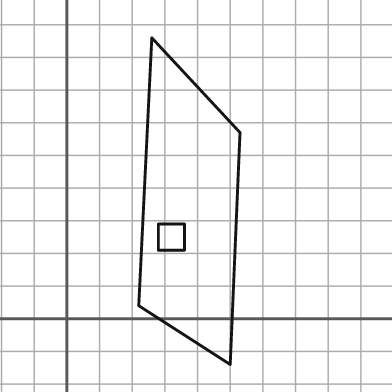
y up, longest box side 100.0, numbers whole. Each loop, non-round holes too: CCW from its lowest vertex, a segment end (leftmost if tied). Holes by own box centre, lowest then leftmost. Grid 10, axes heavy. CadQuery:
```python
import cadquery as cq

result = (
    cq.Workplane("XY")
    .moveTo(50.0, -14.0)
    .lineTo(53.0, 57.0)
    .lineTo(26.0, 86.0)
    .lineTo(22.0, 4.0)
    .close()
    .moveTo(28.0, 21.0)
    .lineTo(36.0, 21.0)
    .lineTo(36.0, 29.0)
    .lineTo(28.0, 29.0)
    .close()
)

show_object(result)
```